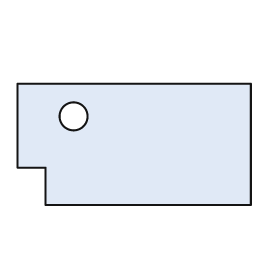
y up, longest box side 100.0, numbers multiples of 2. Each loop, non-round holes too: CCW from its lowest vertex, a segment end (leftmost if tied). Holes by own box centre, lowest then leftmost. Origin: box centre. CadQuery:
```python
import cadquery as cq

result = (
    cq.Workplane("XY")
    .moveTo(-38.0, -26.0)
    .lineTo(50.0, -26.0)
    .lineTo(50.0, 26.0)
    .lineTo(-50.0, 26.0)
    .lineTo(-50.0, -10.0)
    .lineTo(-38.0, -10.0)
    .close()
    .moveTo(-26.0, 12.0)
    .circle(6.0)
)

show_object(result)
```